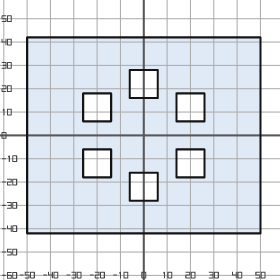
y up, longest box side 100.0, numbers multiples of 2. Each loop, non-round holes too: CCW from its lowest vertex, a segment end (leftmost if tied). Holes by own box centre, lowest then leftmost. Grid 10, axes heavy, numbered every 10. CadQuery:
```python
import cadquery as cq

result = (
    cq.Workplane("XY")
    .moveTo(-50.0, -42.0)
    .lineTo(50.0, -42.0)
    .lineTo(50.0, 42.0)
    .lineTo(-50.0, 42.0)
    .close()
    .moveTo(-6.0, -28.0)
    .lineTo(6.0, -28.0)
    .lineTo(6.0, -16.0)
    .lineTo(-6.0, -16.0)
    .close()
    .moveTo(-26.0, -18.0)
    .lineTo(-14.0, -18.0)
    .lineTo(-14.0, -6.0)
    .lineTo(-26.0, -6.0)
    .close()
    .moveTo(14.0, -18.0)
    .lineTo(26.0, -18.0)
    .lineTo(26.0, -6.0)
    .lineTo(14.0, -6.0)
    .close()
    .moveTo(-26.0, 6.0)
    .lineTo(-14.0, 6.0)
    .lineTo(-14.0, 18.0)
    .lineTo(-26.0, 18.0)
    .close()
    .moveTo(14.0, 6.0)
    .lineTo(26.0, 6.0)
    .lineTo(26.0, 18.0)
    .lineTo(14.0, 18.0)
    .close()
    .moveTo(-6.0, 16.0)
    .lineTo(6.0, 16.0)
    .lineTo(6.0, 28.0)
    .lineTo(-6.0, 28.0)
    .close()
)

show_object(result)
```